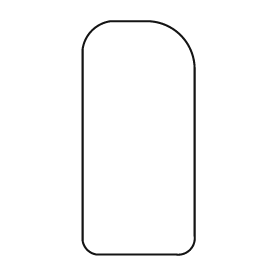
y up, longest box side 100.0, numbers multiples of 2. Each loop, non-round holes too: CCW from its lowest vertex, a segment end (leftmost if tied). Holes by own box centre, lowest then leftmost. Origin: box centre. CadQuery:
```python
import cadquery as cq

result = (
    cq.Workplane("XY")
    .moveTo(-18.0, -50.0)
    .lineTo(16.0, -50.0)
    .threePointArc((22.0, -48.0), (24.0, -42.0))
    .lineTo(24.0, 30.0)
    .threePointArc((18.0, 44.0), (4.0, 50.0))
    .lineTo(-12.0, 50.0)
    .threePointArc((-20.0, 46.0), (-24.0, 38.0))
    .lineTo(-24.0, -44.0)
    .threePointArc((-22.0, -48.0), (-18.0, -50.0))
    .close()
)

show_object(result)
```